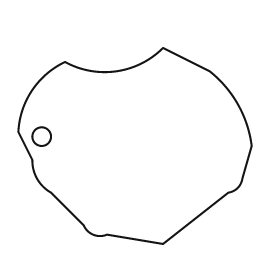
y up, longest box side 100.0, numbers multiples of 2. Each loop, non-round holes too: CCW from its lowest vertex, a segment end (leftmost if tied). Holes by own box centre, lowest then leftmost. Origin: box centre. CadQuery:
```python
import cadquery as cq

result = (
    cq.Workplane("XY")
    .moveTo(12.0, -42.0)
    .lineTo(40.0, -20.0)
    .threePointArc((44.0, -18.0), (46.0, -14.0))
    .lineTo(50.0, 0.0)
    .threePointArc((44.0, 18.0), (32.0, 32.0))
    .lineTo(12.0, 42.0)
    .threePointArc((-8.0, 32.0), (-30.0, 36.0))
    .threePointArc((-44.0, 24.0), (-50.0, 6.0))
    .lineTo(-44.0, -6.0)
    .threePointArc((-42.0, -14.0), (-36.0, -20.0))
    .lineTo(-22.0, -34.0)
    .threePointArc((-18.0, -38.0), (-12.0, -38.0))
    .close()
    .moveTo(-40.0, 4.0)
    .circle(4.0)
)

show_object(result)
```